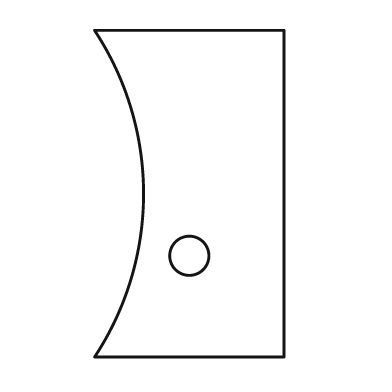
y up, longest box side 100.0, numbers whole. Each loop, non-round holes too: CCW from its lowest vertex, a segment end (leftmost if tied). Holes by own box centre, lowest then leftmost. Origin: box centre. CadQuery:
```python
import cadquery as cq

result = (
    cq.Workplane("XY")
    .moveTo(-29.0, -50.0)
    .lineTo(29.0, -50.0)
    .lineTo(29.0, 50.0)
    .lineTo(-29.0, 50.0)
    .threePointArc((-14.0, 0.0), (-29.0, -50.0))
    .close()
    .moveTo(0.0, -19.0)
    .circle(6.0)
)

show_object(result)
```